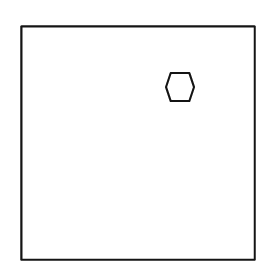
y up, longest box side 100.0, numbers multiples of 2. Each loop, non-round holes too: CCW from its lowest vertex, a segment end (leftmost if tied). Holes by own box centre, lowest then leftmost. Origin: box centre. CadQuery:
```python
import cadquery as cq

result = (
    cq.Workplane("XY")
    .moveTo(-50.0, -50.0)
    .lineTo(50.0, -50.0)
    .lineTo(50.0, 50.0)
    .lineTo(-50.0, 50.0)
    .close()
    .moveTo(14.0, 18.0)
    .lineTo(22.0, 18.0)
    .lineTo(24.0, 24.0)
    .lineTo(22.0, 30.0)
    .lineTo(14.0, 30.0)
    .lineTo(12.0, 24.0)
    .close()
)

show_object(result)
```